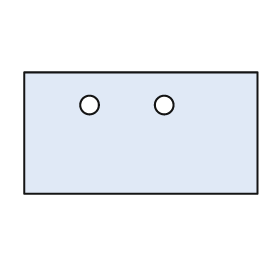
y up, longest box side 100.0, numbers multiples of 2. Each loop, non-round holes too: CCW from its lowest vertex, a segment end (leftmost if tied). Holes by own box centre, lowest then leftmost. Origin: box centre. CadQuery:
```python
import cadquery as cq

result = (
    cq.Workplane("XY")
    .moveTo(-50.0, -26.0)
    .lineTo(50.0, -26.0)
    .lineTo(50.0, 26.0)
    .lineTo(-50.0, 26.0)
    .close()
    .moveTo(-22.0, 12.0)
    .circle(4.0)
    .moveTo(10.0, 12.0)
    .circle(4.0)
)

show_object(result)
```